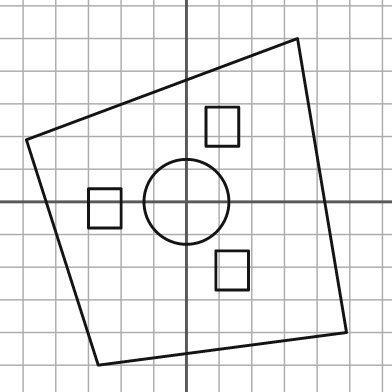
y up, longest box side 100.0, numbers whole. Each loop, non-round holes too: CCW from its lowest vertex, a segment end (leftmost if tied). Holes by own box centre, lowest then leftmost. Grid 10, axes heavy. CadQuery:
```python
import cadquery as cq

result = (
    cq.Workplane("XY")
    .moveTo(-27.0, -50.0)
    .lineTo(49.0, -40.0)
    .lineTo(34.0, 50.0)
    .lineTo(-49.0, 19.0)
    .close()
    .moveTo(9.0, -27.0)
    .lineTo(19.0, -27.0)
    .lineTo(19.0, -15.0)
    .lineTo(9.0, -15.0)
    .close()
    .moveTo(-30.0, -8.0)
    .lineTo(-20.0, -8.0)
    .lineTo(-20.0, 4.0)
    .lineTo(-30.0, 4.0)
    .close()
    .moveTo(0.0, 0.0)
    .circle(13.0)
    .moveTo(6.0, 17.0)
    .lineTo(16.0, 17.0)
    .lineTo(16.0, 29.0)
    .lineTo(6.0, 29.0)
    .close()
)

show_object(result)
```